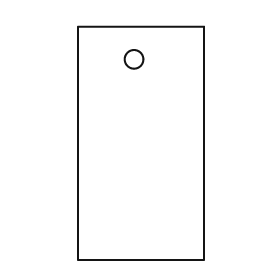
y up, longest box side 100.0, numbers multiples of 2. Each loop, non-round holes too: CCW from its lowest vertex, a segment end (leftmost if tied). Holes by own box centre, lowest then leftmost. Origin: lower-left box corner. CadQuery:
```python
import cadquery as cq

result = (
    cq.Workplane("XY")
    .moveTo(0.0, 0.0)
    .lineTo(54.0, 0.0)
    .lineTo(54.0, 100.0)
    .lineTo(0.0, 100.0)
    .close()
    .moveTo(24.0, 86.0)
    .circle(4.0)
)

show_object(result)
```